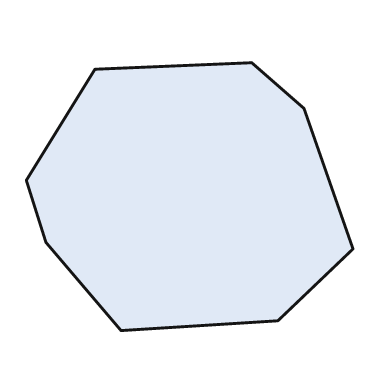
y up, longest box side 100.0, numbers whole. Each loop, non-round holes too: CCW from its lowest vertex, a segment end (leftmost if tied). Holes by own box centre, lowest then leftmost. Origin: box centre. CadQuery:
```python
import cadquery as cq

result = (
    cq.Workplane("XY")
    .moveTo(-21.0, -41.0)
    .lineTo(27.0, -38.0)
    .lineTo(50.0, -16.0)
    .lineTo(35.0, 27.0)
    .lineTo(19.0, 41.0)
    .lineTo(-29.0, 39.0)
    .lineTo(-50.0, 5.0)
    .lineTo(-44.0, -14.0)
    .close()
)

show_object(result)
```